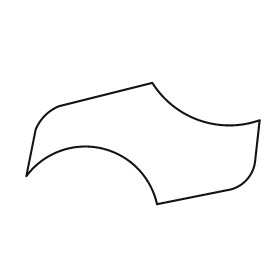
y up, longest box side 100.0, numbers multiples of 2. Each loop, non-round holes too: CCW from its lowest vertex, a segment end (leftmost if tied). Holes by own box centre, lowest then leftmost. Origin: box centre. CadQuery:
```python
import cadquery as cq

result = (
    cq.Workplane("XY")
    .moveTo(6.0, -26.0)
    .lineTo(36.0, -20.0)
    .threePointArc((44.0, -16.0), (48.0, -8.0))
    .lineTo(50.0, 10.0)
    .threePointArc((24.0, 10.0), (4.0, 26.0))
    .lineTo(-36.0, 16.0)
    .threePointArc((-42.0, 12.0), (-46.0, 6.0))
    .lineTo(-50.0, -14.0)
    .threePointArc((-18.0, -2.0), (6.0, -26.0))
    .close()
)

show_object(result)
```